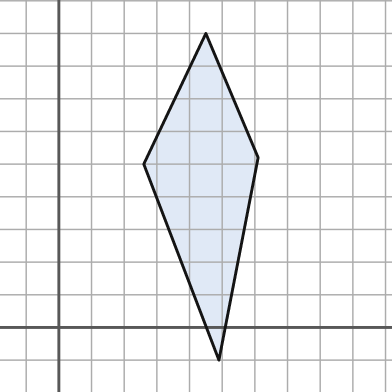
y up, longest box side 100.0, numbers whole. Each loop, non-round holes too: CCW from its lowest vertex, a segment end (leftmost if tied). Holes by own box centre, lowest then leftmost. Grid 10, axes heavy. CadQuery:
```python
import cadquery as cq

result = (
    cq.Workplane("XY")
    .moveTo(49.0, -10.0)
    .lineTo(61.0, 52.0)
    .lineTo(45.0, 90.0)
    .lineTo(26.0, 50.0)
    .close()
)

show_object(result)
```